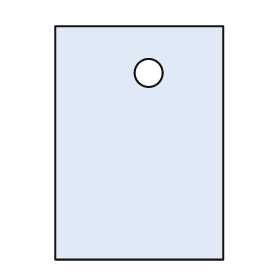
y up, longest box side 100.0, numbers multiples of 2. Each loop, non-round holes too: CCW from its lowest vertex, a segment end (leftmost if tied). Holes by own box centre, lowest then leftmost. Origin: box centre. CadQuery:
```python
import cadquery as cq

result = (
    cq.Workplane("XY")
    .moveTo(-36.0, -50.0)
    .lineTo(36.0, -50.0)
    .lineTo(36.0, 50.0)
    .lineTo(-36.0, 50.0)
    .close()
    .moveTo(4.0, 30.0)
    .circle(6.0)
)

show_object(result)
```